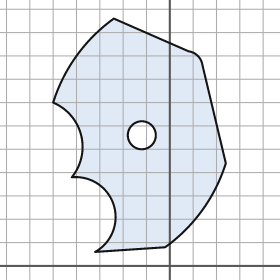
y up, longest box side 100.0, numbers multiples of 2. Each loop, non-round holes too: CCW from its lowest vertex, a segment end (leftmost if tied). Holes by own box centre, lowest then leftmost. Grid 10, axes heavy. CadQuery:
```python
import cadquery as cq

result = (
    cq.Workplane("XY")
    .moveTo(-32.0, 6.0)
    .lineTo(-2.0, 8.0)
    .threePointArc((14.0, 24.0), (24.0, 44.0))
    .lineTo(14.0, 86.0)
    .threePointArc((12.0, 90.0), (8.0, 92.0))
    .lineTo(-24.0, 106.0)
    .threePointArc((-40.0, 90.0), (-50.0, 70.0))
    .threePointArc((-38.0, 56.0), (-42.0, 38.0))
    .threePointArc((-24.0, 26.0), (-32.0, 6.0))
    .close()
    .moveTo(-12.0, 56.0)
    .circle(6.0)
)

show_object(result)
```